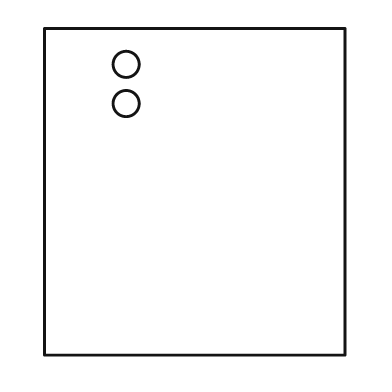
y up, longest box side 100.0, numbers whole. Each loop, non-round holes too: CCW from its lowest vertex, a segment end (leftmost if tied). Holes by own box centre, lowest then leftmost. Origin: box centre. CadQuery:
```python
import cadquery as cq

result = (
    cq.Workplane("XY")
    .moveTo(-46.0, -50.0)
    .lineTo(46.0, -50.0)
    .lineTo(46.0, 50.0)
    .lineTo(-46.0, 50.0)
    .close()
    .moveTo(-21.0, 27.0)
    .circle(4.0)
    .moveTo(-21.0, 39.0)
    .circle(4.0)
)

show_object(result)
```